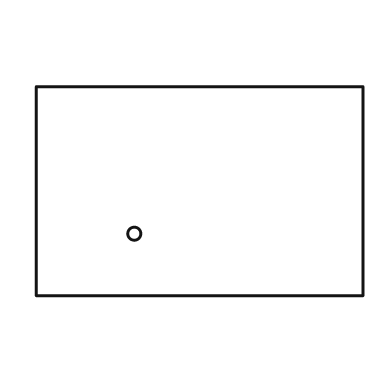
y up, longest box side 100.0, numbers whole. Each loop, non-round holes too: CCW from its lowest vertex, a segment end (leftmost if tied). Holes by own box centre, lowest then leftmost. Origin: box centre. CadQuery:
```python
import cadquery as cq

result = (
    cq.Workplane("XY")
    .moveTo(-50.0, -32.0)
    .lineTo(50.0, -32.0)
    .lineTo(50.0, 32.0)
    .lineTo(-50.0, 32.0)
    .close()
    .moveTo(-20.0, -13.0)
    .circle(2.0)
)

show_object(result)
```